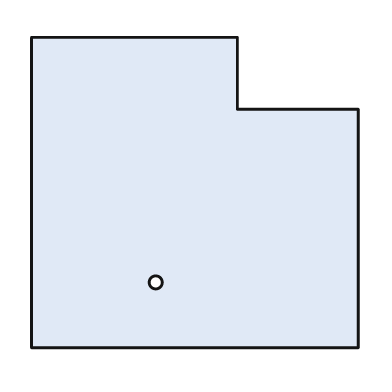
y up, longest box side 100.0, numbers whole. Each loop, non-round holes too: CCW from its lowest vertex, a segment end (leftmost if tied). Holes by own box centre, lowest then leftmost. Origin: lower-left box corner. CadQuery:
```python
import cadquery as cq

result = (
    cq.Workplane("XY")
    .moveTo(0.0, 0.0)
    .lineTo(100.0, 0.0)
    .lineTo(100.0, 73.0)
    .lineTo(63.0, 73.0)
    .lineTo(63.0, 95.0)
    .lineTo(0.0, 95.0)
    .close()
    .moveTo(38.0, 20.0)
    .circle(2.0)
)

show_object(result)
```